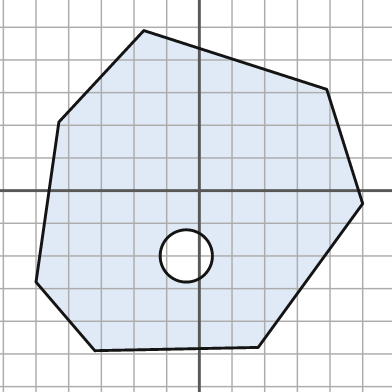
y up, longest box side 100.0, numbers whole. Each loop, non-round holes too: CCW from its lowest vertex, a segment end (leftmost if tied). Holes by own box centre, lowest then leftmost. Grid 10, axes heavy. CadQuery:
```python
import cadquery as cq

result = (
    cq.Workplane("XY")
    .moveTo(-32.0, -49.0)
    .lineTo(18.0, -48.0)
    .lineTo(50.0, -4.0)
    .lineTo(39.0, 31.0)
    .lineTo(-17.0, 49.0)
    .lineTo(-43.0, 21.0)
    .lineTo(-50.0, -28.0)
    .close()
    .moveTo(-4.0, -20.0)
    .circle(8.0)
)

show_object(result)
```